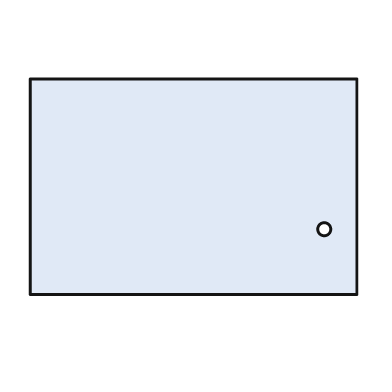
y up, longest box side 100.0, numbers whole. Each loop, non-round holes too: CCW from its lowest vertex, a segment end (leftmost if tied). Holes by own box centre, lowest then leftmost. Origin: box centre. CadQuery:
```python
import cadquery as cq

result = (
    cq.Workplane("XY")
    .moveTo(-50.0, -33.0)
    .lineTo(50.0, -33.0)
    .lineTo(50.0, 33.0)
    .lineTo(-50.0, 33.0)
    .close()
    .moveTo(40.0, -13.0)
    .circle(2.0)
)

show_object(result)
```